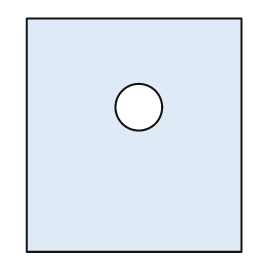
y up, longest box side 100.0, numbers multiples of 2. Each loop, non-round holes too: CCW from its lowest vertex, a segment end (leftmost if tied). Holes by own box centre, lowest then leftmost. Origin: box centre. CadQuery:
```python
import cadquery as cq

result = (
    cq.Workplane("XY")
    .moveTo(-46.0, -50.0)
    .lineTo(46.0, -50.0)
    .lineTo(46.0, 50.0)
    .lineTo(-46.0, 50.0)
    .close()
    .moveTo(2.0, 12.0)
    .circle(10.0)
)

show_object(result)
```